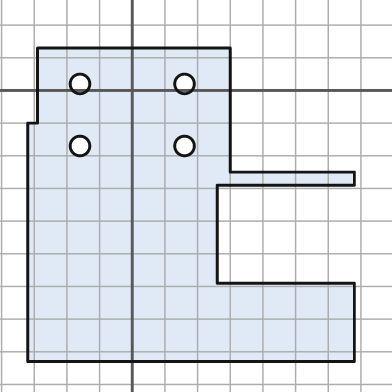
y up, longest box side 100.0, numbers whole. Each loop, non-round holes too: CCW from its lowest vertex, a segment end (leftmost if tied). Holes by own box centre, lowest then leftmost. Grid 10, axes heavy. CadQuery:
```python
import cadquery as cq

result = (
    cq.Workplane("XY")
    .moveTo(-32.0, -83.0)
    .lineTo(68.0, -83.0)
    .lineTo(68.0, -59.0)
    .lineTo(26.0, -59.0)
    .lineTo(26.0, -29.0)
    .lineTo(68.0, -29.0)
    .lineTo(68.0, -25.0)
    .lineTo(30.0, -25.0)
    .lineTo(30.0, 13.0)
    .lineTo(-29.0, 13.0)
    .lineTo(-29.0, -10.0)
    .lineTo(-32.0, -10.0)
    .close()
    .moveTo(-16.0, -17.0)
    .circle(3.0)
    .moveTo(16.0, -17.0)
    .circle(3.0)
    .moveTo(-16.0, 2.0)
    .circle(3.0)
    .moveTo(16.0, 2.0)
    .circle(3.0)
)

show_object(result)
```